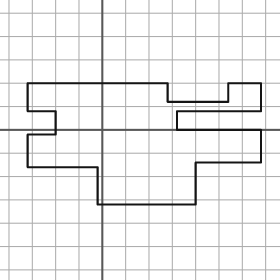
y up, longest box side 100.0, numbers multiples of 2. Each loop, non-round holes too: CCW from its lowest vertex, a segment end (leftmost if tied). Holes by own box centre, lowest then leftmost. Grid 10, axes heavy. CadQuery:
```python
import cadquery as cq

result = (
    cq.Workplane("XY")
    .moveTo(-2.0, -32.0)
    .lineTo(40.0, -32.0)
    .lineTo(40.0, -14.0)
    .lineTo(68.0, -14.0)
    .lineTo(68.0, 0.0)
    .lineTo(32.0, 0.0)
    .lineTo(32.0, 8.0)
    .lineTo(68.0, 8.0)
    .lineTo(68.0, 20.0)
    .lineTo(54.0, 20.0)
    .lineTo(54.0, 12.0)
    .lineTo(28.0, 12.0)
    .lineTo(28.0, 20.0)
    .lineTo(-32.0, 20.0)
    .lineTo(-32.0, 8.0)
    .lineTo(-20.0, 8.0)
    .lineTo(-20.0, -2.0)
    .lineTo(-32.0, -2.0)
    .lineTo(-32.0, -16.0)
    .lineTo(-2.0, -16.0)
    .close()
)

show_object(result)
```